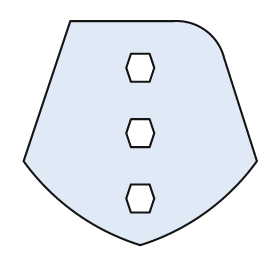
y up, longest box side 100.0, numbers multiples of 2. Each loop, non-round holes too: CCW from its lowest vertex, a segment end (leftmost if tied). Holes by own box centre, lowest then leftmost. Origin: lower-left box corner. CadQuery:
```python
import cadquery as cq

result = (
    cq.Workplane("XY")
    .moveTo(50.0, 0.0)
    .threePointArc((78.0, 14.0), (100.0, 36.0))
    .lineTo(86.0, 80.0)
    .threePointArc((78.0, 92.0), (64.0, 96.0))
    .lineTo(20.0, 96.0)
    .lineTo(0.0, 36.0)
    .threePointArc((22.0, 14.0), (50.0, 0.0))
    .close()
    .moveTo(46.0, 14.0)
    .lineTo(54.0, 14.0)
    .lineTo(56.0, 20.0)
    .lineTo(54.0, 26.0)
    .lineTo(46.0, 26.0)
    .lineTo(44.0, 20.0)
    .close()
    .moveTo(46.0, 42.0)
    .lineTo(54.0, 42.0)
    .lineTo(56.0, 48.0)
    .lineTo(54.0, 54.0)
    .lineTo(46.0, 54.0)
    .lineTo(44.0, 48.0)
    .close()
    .moveTo(46.0, 70.0)
    .lineTo(54.0, 70.0)
    .lineTo(56.0, 76.0)
    .lineTo(54.0, 82.0)
    .lineTo(46.0, 82.0)
    .lineTo(44.0, 76.0)
    .close()
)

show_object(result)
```